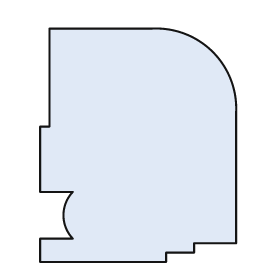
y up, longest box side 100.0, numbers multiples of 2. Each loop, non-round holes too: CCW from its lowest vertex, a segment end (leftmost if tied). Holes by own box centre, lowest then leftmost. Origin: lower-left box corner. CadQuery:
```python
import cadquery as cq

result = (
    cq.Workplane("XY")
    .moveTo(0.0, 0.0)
    .lineTo(54.0, 0.0)
    .lineTo(54.0, 4.0)
    .lineTo(66.0, 4.0)
    .lineTo(66.0, 8.0)
    .lineTo(84.0, 8.0)
    .lineTo(84.0, 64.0)
    .threePointArc((74.0, 90.0), (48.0, 100.0))
    .lineTo(4.0, 100.0)
    .lineTo(4.0, 58.0)
    .lineTo(0.0, 58.0)
    .lineTo(0.0, 30.0)
    .lineTo(14.0, 30.0)
    .threePointArc((10.0, 20.0), (14.0, 10.0))
    .lineTo(0.0, 10.0)
    .close()
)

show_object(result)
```